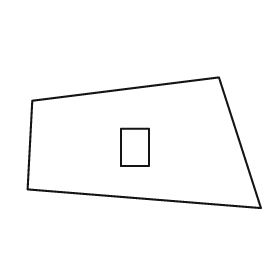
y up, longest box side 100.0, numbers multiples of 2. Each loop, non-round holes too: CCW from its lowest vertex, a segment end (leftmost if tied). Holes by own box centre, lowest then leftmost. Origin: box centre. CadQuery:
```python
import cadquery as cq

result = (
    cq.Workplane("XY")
    .moveTo(50.0, -28.0)
    .lineTo(32.0, 28.0)
    .lineTo(-48.0, 18.0)
    .lineTo(-50.0, -20.0)
    .close()
    .moveTo(-10.0, -10.0)
    .lineTo(2.0, -10.0)
    .lineTo(2.0, 6.0)
    .lineTo(-10.0, 6.0)
    .close()
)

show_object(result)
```